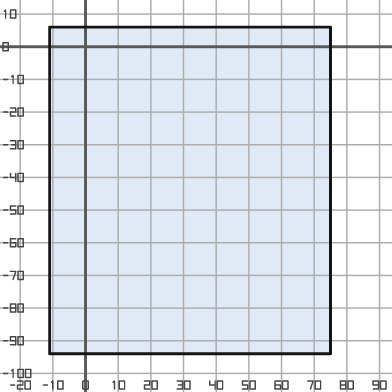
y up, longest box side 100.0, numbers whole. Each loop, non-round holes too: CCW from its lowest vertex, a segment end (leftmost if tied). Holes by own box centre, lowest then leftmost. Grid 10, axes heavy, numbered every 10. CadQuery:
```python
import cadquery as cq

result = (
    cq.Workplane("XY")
    .moveTo(-11.0, -94.0)
    .lineTo(75.0, -94.0)
    .lineTo(75.0, 6.0)
    .lineTo(-11.0, 6.0)
    .close()
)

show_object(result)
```